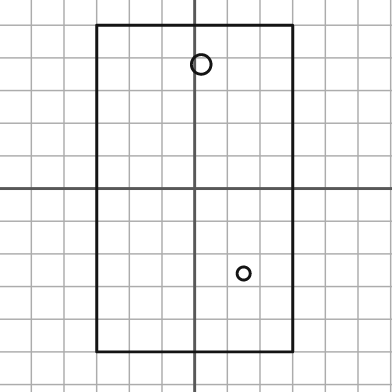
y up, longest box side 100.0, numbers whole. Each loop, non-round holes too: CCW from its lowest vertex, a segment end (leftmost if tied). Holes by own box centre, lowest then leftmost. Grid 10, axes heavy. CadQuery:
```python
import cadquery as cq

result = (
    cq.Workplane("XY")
    .moveTo(-30.0, -50.0)
    .lineTo(30.0, -50.0)
    .lineTo(30.0, 50.0)
    .lineTo(-30.0, 50.0)
    .close()
    .moveTo(15.0, -26.0)
    .circle(2.0)
    .moveTo(2.0, 38.0)
    .circle(3.0)
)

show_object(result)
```